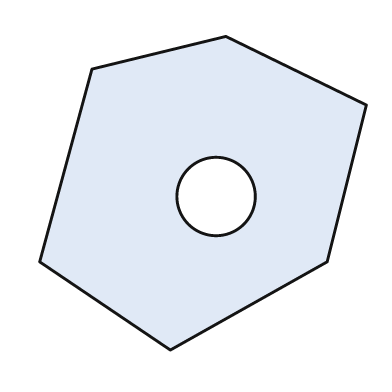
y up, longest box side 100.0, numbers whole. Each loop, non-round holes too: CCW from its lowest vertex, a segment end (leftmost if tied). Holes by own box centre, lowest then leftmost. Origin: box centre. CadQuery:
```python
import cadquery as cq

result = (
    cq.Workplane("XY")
    .moveTo(-10.0, -48.0)
    .lineTo(38.0, -21.0)
    .lineTo(50.0, 27.0)
    .lineTo(7.0, 48.0)
    .lineTo(-34.0, 38.0)
    .lineTo(-50.0, -21.0)
    .close()
    .moveTo(4.0, -1.0)
    .circle(12.0)
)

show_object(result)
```